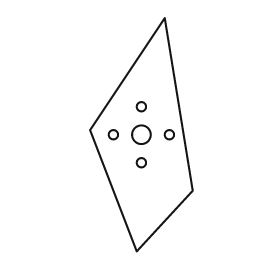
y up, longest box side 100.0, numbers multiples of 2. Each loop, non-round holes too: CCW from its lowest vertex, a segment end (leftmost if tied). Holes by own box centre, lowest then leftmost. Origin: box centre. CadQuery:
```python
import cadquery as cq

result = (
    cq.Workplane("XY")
    .moveTo(-2.0, -50.0)
    .lineTo(22.0, -24.0)
    .lineTo(10.0, 50.0)
    .lineTo(-22.0, 2.0)
    .close()
    .moveTo(0.0, -12.0)
    .circle(2.0)
    .moveTo(-12.0, 0.0)
    .circle(2.0)
    .moveTo(0.0, 0.0)
    .circle(4.0)
    .moveTo(12.0, 0.0)
    .circle(2.0)
    .moveTo(0.0, 12.0)
    .circle(2.0)
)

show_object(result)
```